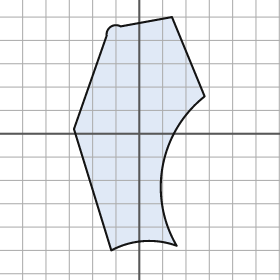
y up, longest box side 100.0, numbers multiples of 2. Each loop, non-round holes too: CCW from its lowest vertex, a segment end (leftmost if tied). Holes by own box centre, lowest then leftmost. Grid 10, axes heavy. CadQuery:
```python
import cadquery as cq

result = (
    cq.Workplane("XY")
    .moveTo(-12.0, -50.0)
    .threePointArc((2.0, -46.0), (16.0, -48.0))
    .threePointArc((10.0, -14.0), (28.0, 16.0))
    .lineTo(14.0, 50.0)
    .lineTo(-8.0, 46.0)
    .threePointArc((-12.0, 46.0), (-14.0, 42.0))
    .lineTo(-28.0, 2.0)
    .close()
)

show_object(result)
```